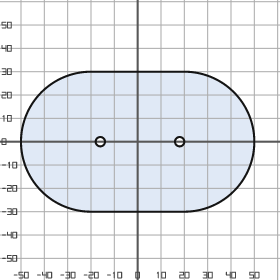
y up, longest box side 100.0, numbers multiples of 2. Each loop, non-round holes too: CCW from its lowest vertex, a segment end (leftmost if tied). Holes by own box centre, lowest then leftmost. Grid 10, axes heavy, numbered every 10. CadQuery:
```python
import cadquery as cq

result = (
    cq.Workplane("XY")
    .moveTo(-20.0, -30.0)
    .lineTo(20.0, -30.0)
    .threePointArc((50.0, 0.0), (20.0, 30.0))
    .lineTo(-20.0, 30.0)
    .threePointArc((-50.0, 0.0), (-20.0, -30.0))
    .close()
    .moveTo(-16.0, 0.0)
    .circle(2.0)
    .moveTo(18.0, 0.0)
    .circle(2.0)
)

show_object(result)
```